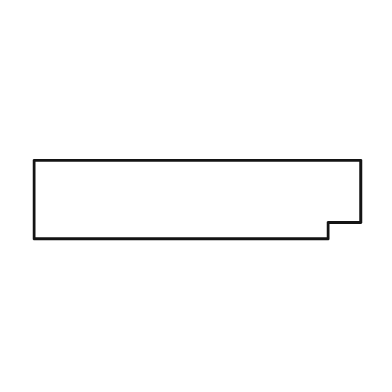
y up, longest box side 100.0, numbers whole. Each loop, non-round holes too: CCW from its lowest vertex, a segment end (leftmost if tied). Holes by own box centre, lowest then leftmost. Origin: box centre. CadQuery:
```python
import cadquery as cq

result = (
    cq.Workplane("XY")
    .moveTo(-50.0, -12.0)
    .lineTo(40.0, -12.0)
    .lineTo(40.0, -7.0)
    .lineTo(50.0, -7.0)
    .lineTo(50.0, 12.0)
    .lineTo(-50.0, 12.0)
    .close()
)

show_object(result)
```